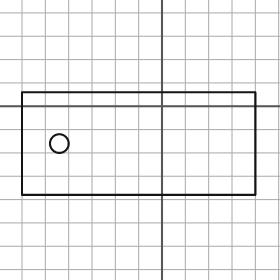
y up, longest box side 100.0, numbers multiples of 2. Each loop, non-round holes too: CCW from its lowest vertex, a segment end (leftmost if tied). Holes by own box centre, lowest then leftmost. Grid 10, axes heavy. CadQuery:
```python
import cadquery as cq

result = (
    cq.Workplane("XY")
    .moveTo(-60.0, -38.0)
    .lineTo(40.0, -38.0)
    .lineTo(40.0, 6.0)
    .lineTo(-60.0, 6.0)
    .close()
    .moveTo(-44.0, -16.0)
    .circle(4.0)
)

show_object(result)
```